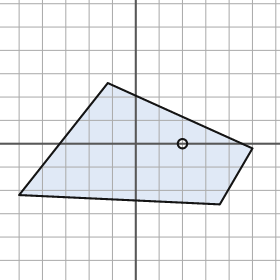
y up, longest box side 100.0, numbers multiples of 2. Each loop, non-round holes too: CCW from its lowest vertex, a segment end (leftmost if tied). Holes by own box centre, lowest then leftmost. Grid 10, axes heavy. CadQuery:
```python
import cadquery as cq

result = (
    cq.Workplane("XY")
    .moveTo(36.0, -26.0)
    .lineTo(50.0, -2.0)
    .lineTo(-12.0, 26.0)
    .lineTo(-50.0, -22.0)
    .close()
    .moveTo(20.0, 0.0)
    .circle(2.0)
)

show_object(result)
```